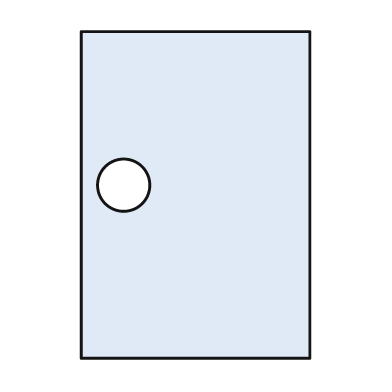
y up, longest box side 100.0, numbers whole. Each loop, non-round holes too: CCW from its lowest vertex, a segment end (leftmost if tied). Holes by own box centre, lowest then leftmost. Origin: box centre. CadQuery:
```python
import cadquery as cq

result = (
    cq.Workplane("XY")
    .moveTo(-35.0, -50.0)
    .lineTo(35.0, -50.0)
    .lineTo(35.0, 50.0)
    .lineTo(-35.0, 50.0)
    .close()
    .moveTo(-22.0, 3.0)
    .circle(8.0)
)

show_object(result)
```